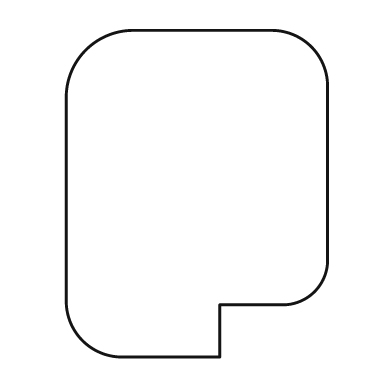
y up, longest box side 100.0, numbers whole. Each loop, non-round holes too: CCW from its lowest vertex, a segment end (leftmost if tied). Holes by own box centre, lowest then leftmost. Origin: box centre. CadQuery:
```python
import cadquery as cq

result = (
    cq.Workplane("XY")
    .moveTo(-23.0, -50.0)
    .lineTo(7.0, -50.0)
    .lineTo(7.0, -34.0)
    .lineTo(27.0, -34.0)
    .threePointArc((36.0, -30.0), (40.0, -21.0))
    .lineTo(40.0, 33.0)
    .threePointArc((35.0, 45.0), (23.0, 50.0))
    .lineTo(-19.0, 50.0)
    .threePointArc((-34.0, 44.0), (-40.0, 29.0))
    .lineTo(-40.0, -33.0)
    .threePointArc((-35.0, -45.0), (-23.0, -50.0))
    .close()
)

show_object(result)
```